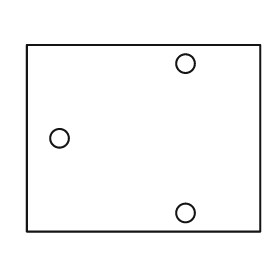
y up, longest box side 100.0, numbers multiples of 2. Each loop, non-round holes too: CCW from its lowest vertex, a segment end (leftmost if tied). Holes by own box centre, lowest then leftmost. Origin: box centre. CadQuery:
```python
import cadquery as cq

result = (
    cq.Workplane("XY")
    .moveTo(-50.0, -40.0)
    .lineTo(50.0, -40.0)
    .lineTo(50.0, 40.0)
    .lineTo(-50.0, 40.0)
    .close()
    .moveTo(18.0, -32.0)
    .circle(4.0)
    .moveTo(-36.0, 0.0)
    .circle(4.0)
    .moveTo(18.0, 32.0)
    .circle(4.0)
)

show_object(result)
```